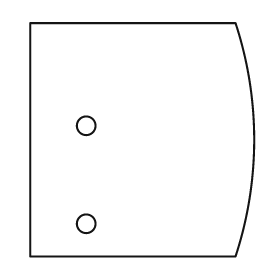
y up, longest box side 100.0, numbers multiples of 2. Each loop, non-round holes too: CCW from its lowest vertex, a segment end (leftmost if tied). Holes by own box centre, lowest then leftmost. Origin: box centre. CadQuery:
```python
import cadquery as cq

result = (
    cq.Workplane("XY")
    .moveTo(-48.0, -50.0)
    .lineTo(40.0, -50.0)
    .threePointArc((48.0, 0.0), (40.0, 50.0))
    .lineTo(-48.0, 50.0)
    .close()
    .moveTo(-24.0, -36.0)
    .circle(4.0)
    .moveTo(-24.0, 6.0)
    .circle(4.0)
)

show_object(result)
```